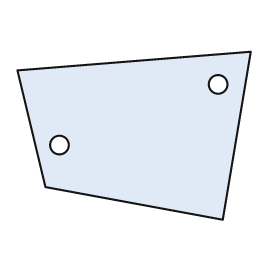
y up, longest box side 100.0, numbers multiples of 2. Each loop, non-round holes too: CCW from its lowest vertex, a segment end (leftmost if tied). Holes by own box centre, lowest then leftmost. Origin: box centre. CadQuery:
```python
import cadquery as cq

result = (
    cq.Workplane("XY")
    .moveTo(38.0, -36.0)
    .lineTo(50.0, 36.0)
    .lineTo(-50.0, 28.0)
    .lineTo(-38.0, -22.0)
    .close()
    .moveTo(-32.0, -4.0)
    .circle(4.0)
    .moveTo(36.0, 22.0)
    .circle(4.0)
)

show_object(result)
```